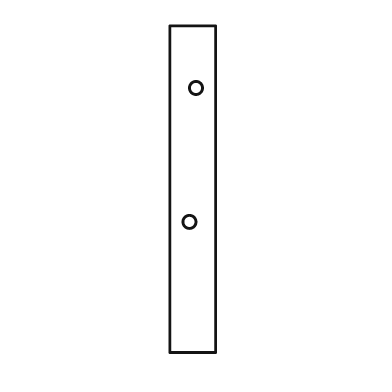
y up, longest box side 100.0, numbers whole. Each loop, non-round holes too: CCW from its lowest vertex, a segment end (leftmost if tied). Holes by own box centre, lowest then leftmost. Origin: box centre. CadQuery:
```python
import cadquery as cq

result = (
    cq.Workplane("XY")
    .moveTo(-7.0, -50.0)
    .lineTo(7.0, -50.0)
    .lineTo(7.0, 50.0)
    .lineTo(-7.0, 50.0)
    .close()
    .moveTo(-1.0, -10.0)
    .circle(2.0)
    .moveTo(1.0, 31.0)
    .circle(2.0)
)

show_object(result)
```